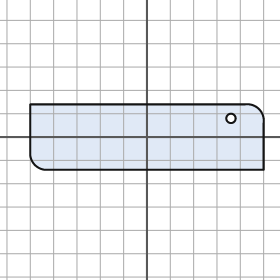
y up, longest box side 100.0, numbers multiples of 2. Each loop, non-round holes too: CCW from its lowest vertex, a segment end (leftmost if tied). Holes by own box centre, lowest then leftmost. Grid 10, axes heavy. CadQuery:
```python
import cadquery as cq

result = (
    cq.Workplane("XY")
    .moveTo(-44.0, -14.0)
    .lineTo(50.0, -14.0)
    .lineTo(50.0, 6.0)
    .threePointArc((48.0, 12.0), (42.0, 14.0))
    .lineTo(-50.0, 14.0)
    .lineTo(-50.0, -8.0)
    .threePointArc((-48.0, -12.0), (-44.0, -14.0))
    .close()
    .moveTo(36.0, 8.0)
    .circle(2.0)
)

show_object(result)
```